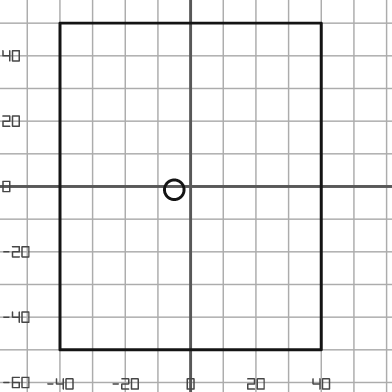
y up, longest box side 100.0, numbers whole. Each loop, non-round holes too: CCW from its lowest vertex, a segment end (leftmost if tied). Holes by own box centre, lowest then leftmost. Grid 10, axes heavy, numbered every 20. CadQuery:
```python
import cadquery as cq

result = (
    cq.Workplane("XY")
    .moveTo(-40.0, -50.0)
    .lineTo(40.0, -50.0)
    .lineTo(40.0, 50.0)
    .lineTo(-40.0, 50.0)
    .close()
    .moveTo(-5.0, -1.0)
    .circle(3.0)
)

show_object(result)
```